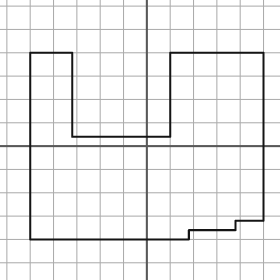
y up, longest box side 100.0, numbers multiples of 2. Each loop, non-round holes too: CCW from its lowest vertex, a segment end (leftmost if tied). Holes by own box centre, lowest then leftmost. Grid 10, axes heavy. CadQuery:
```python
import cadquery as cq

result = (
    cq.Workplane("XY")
    .moveTo(-50.0, -40.0)
    .lineTo(18.0, -40.0)
    .lineTo(18.0, -36.0)
    .lineTo(38.0, -36.0)
    .lineTo(38.0, -32.0)
    .lineTo(50.0, -32.0)
    .lineTo(50.0, 40.0)
    .lineTo(10.0, 40.0)
    .lineTo(10.0, 4.0)
    .lineTo(-32.0, 4.0)
    .lineTo(-32.0, 40.0)
    .lineTo(-50.0, 40.0)
    .close()
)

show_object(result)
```